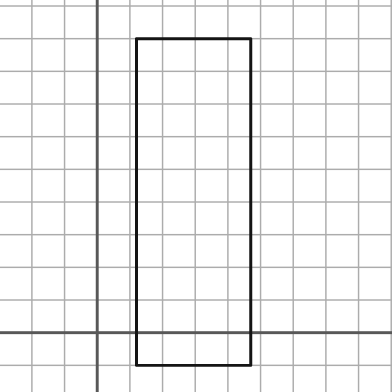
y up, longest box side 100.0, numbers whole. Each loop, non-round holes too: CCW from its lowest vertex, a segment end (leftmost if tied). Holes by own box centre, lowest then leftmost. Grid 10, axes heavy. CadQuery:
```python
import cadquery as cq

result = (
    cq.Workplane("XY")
    .moveTo(12.0, -10.0)
    .lineTo(47.0, -10.0)
    .lineTo(47.0, 90.0)
    .lineTo(12.0, 90.0)
    .close()
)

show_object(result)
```